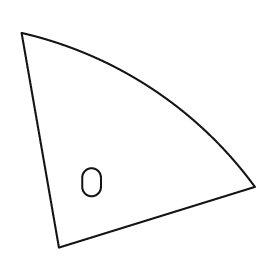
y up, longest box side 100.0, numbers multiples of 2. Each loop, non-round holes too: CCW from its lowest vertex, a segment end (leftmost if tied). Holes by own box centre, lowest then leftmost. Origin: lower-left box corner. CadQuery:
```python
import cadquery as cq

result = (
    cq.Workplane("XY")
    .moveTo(16.0, 0.0)
    .lineTo(100.0, 26.0)
    .threePointArc((56.0, 68.0), (0.0, 92.0))
    .close()
    .moveTo(26.0, 26.0)
    .threePointArc((30.0, 22.0), (34.0, 26.0))
    .lineTo(34.0, 30.0)
    .threePointArc((30.0, 34.0), (26.0, 30.0))
    .close()
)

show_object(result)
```